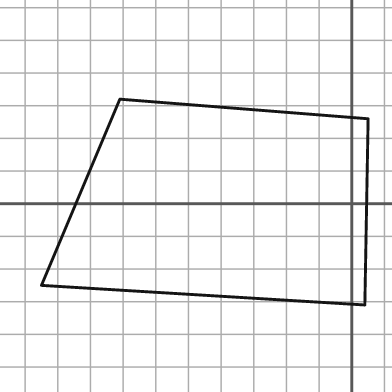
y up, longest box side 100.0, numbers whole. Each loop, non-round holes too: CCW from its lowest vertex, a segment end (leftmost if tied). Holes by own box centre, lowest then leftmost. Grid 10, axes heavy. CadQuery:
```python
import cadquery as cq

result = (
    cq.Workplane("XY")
    .moveTo(4.0, -31.0)
    .lineTo(5.0, 26.0)
    .lineTo(-71.0, 32.0)
    .lineTo(-95.0, -25.0)
    .close()
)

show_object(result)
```